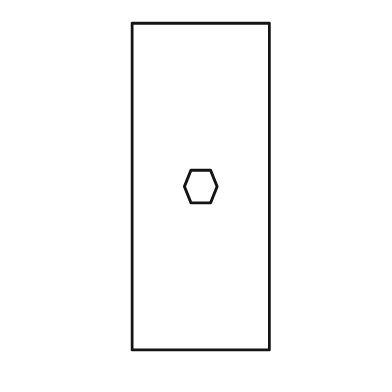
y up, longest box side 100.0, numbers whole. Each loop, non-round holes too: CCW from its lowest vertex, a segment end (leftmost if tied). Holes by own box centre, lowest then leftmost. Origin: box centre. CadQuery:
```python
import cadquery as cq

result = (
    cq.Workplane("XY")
    .moveTo(-21.0, -50.0)
    .lineTo(21.0, -50.0)
    .lineTo(21.0, 50.0)
    .lineTo(-21.0, 50.0)
    .close()
    .moveTo(-3.0, -5.0)
    .lineTo(3.0, -5.0)
    .lineTo(5.0, 0.0)
    .lineTo(3.0, 5.0)
    .lineTo(-3.0, 5.0)
    .lineTo(-5.0, 0.0)
    .close()
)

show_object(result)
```